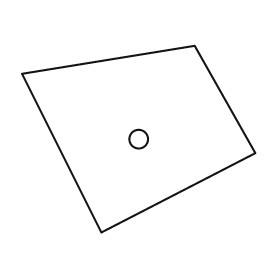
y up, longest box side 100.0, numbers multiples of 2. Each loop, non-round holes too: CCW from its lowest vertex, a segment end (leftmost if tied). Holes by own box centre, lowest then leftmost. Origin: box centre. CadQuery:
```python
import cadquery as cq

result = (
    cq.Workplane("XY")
    .moveTo(-16.0, -40.0)
    .lineTo(50.0, -6.0)
    .lineTo(24.0, 40.0)
    .lineTo(-50.0, 28.0)
    .close()
    .moveTo(0.0, 0.0)
    .circle(4.0)
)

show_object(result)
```